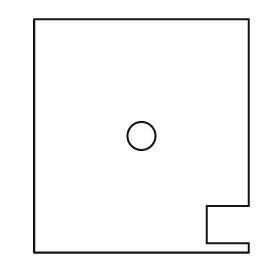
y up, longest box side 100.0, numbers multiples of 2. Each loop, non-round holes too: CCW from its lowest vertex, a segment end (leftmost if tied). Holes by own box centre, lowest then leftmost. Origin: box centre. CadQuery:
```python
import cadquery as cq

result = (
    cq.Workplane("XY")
    .moveTo(-46.0, -50.0)
    .lineTo(46.0, -50.0)
    .lineTo(46.0, -46.0)
    .lineTo(28.0, -46.0)
    .lineTo(28.0, -30.0)
    .lineTo(46.0, -30.0)
    .lineTo(46.0, 50.0)
    .lineTo(-46.0, 50.0)
    .close()
    .moveTo(0.0, 0.0)
    .circle(6.0)
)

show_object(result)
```